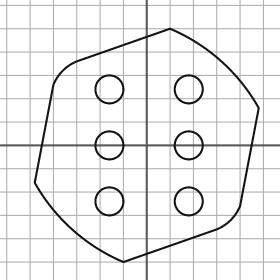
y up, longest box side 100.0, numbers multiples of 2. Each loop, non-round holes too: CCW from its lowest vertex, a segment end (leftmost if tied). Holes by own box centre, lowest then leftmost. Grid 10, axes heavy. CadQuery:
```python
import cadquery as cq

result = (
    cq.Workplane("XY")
    .moveTo(-10.0, -50.0)
    .lineTo(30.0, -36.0)
    .threePointArc((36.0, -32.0), (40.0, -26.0))
    .lineTo(48.0, 16.0)
    .threePointArc((32.0, 36.0), (10.0, 50.0))
    .lineTo(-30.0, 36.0)
    .threePointArc((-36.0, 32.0), (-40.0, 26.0))
    .lineTo(-48.0, -16.0)
    .threePointArc((-32.0, -36.0), (-10.0, -50.0))
    .close()
    .moveTo(-16.0, -24.0)
    .circle(6.0)
    .moveTo(18.0, -24.0)
    .circle(6.0)
    .moveTo(-16.0, 0.0)
    .circle(6.0)
    .moveTo(18.0, 0.0)
    .circle(6.0)
    .moveTo(-16.0, 24.0)
    .circle(6.0)
    .moveTo(18.0, 24.0)
    .circle(6.0)
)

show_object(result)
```